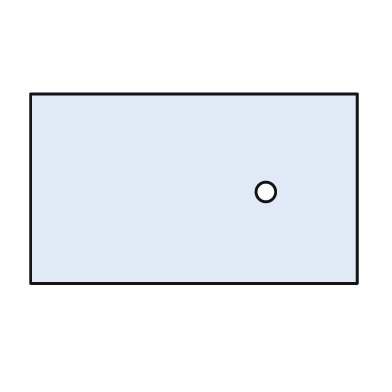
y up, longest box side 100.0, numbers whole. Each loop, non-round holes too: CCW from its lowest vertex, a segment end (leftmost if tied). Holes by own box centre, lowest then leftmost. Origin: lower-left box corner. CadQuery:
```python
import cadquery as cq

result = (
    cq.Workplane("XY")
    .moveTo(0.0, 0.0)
    .lineTo(100.0, 0.0)
    .lineTo(100.0, 58.0)
    .lineTo(0.0, 58.0)
    .close()
    .moveTo(72.0, 28.0)
    .circle(3.0)
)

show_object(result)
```